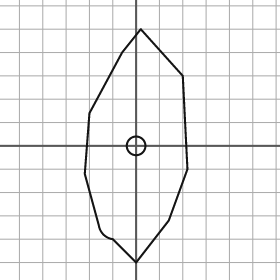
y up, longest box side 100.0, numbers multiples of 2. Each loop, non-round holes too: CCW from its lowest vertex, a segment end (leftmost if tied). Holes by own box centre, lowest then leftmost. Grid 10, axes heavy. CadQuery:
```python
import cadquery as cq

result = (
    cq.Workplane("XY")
    .moveTo(0.0, -50.0)
    .lineTo(14.0, -32.0)
    .lineTo(22.0, -10.0)
    .lineTo(20.0, 30.0)
    .lineTo(2.0, 50.0)
    .lineTo(-6.0, 40.0)
    .lineTo(-20.0, 14.0)
    .lineTo(-22.0, -12.0)
    .lineTo(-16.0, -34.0)
    .threePointArc((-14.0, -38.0), (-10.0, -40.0))
    .close()
    .moveTo(0.0, 0.0)
    .circle(4.0)
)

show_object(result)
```